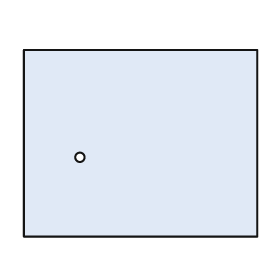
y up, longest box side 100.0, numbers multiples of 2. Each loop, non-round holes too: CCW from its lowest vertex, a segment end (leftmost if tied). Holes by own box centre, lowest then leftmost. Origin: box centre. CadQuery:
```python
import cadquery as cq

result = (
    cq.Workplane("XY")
    .moveTo(-50.0, -40.0)
    .lineTo(50.0, -40.0)
    .lineTo(50.0, 40.0)
    .lineTo(-50.0, 40.0)
    .close()
    .moveTo(-26.0, -6.0)
    .circle(2.0)
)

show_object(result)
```